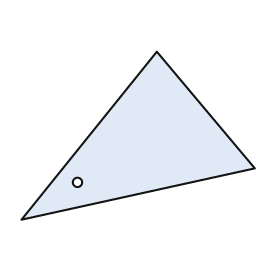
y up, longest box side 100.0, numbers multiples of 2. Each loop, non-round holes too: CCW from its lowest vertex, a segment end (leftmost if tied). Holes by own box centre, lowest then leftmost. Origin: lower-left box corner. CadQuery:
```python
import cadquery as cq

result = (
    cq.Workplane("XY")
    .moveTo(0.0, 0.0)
    .lineTo(100.0, 22.0)
    .lineTo(58.0, 72.0)
    .close()
    .moveTo(24.0, 16.0)
    .circle(2.0)
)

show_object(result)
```